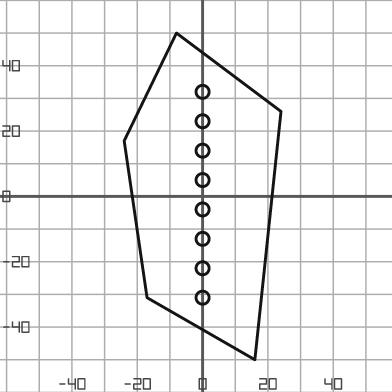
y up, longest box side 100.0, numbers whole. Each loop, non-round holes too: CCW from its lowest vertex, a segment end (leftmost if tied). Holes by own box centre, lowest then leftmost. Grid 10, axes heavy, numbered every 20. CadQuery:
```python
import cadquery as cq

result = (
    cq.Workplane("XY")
    .moveTo(16.0, -50.0)
    .lineTo(24.0, 26.0)
    .lineTo(-8.0, 50.0)
    .lineTo(-24.0, 17.0)
    .lineTo(-17.0, -31.0)
    .close()
    .moveTo(0.0, -31.0)
    .circle(2.0)
    .moveTo(0.0, -22.0)
    .circle(2.0)
    .moveTo(0.0, -13.0)
    .circle(2.0)
    .moveTo(0.0, -4.0)
    .circle(2.0)
    .moveTo(0.0, 5.0)
    .circle(2.0)
    .moveTo(0.0, 14.0)
    .circle(2.0)
    .moveTo(0.0, 23.0)
    .circle(2.0)
    .moveTo(0.0, 32.0)
    .circle(2.0)
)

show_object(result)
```